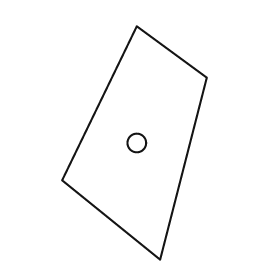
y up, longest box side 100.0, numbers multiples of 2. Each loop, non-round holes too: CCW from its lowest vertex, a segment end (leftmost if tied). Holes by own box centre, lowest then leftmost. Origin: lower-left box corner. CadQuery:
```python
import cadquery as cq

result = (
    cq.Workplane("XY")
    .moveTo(42.0, 0.0)
    .lineTo(62.0, 78.0)
    .lineTo(32.0, 100.0)
    .lineTo(0.0, 34.0)
    .close()
    .moveTo(32.0, 50.0)
    .circle(4.0)
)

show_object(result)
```